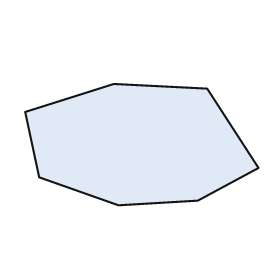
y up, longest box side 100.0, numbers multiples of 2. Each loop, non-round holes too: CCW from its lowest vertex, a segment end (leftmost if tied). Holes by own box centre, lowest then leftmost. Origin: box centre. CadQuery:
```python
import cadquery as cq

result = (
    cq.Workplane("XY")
    .moveTo(-10.0, -26.0)
    .lineTo(24.0, -24.0)
    .lineTo(50.0, -10.0)
    .lineTo(28.0, 24.0)
    .lineTo(-12.0, 26.0)
    .lineTo(-50.0, 14.0)
    .lineTo(-44.0, -14.0)
    .close()
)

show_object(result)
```